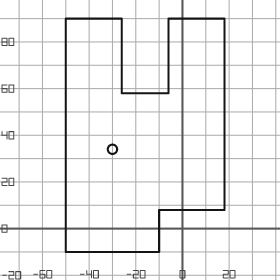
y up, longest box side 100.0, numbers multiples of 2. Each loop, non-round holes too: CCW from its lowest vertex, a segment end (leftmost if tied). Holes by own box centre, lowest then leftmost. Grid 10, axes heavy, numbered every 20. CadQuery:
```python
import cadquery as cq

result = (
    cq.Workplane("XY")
    .moveTo(-50.0, -10.0)
    .lineTo(-10.0, -10.0)
    .lineTo(-10.0, 8.0)
    .lineTo(18.0, 8.0)
    .lineTo(18.0, 90.0)
    .lineTo(-6.0, 90.0)
    .lineTo(-6.0, 58.0)
    .lineTo(-26.0, 58.0)
    .lineTo(-26.0, 90.0)
    .lineTo(-50.0, 90.0)
    .close()
    .moveTo(-30.0, 34.0)
    .circle(2.0)
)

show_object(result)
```